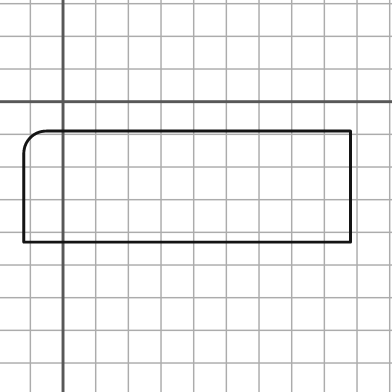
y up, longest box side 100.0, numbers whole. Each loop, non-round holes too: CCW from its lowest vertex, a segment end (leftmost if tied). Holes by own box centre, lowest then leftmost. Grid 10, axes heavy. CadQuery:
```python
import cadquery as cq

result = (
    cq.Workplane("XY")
    .moveTo(-12.0, -43.0)
    .lineTo(88.0, -43.0)
    .lineTo(88.0, -9.0)
    .lineTo(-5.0, -9.0)
    .threePointArc((-10.0, -11.0), (-12.0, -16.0))
    .close()
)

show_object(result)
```